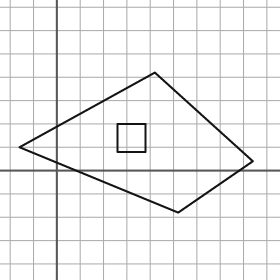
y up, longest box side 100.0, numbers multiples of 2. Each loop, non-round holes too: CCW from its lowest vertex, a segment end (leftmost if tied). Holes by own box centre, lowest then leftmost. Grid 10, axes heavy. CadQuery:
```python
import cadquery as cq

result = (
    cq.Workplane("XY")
    .moveTo(52.0, -18.0)
    .lineTo(84.0, 4.0)
    .lineTo(42.0, 42.0)
    .lineTo(-16.0, 10.0)
    .close()
    .moveTo(26.0, 8.0)
    .lineTo(38.0, 8.0)
    .lineTo(38.0, 20.0)
    .lineTo(26.0, 20.0)
    .close()
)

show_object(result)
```